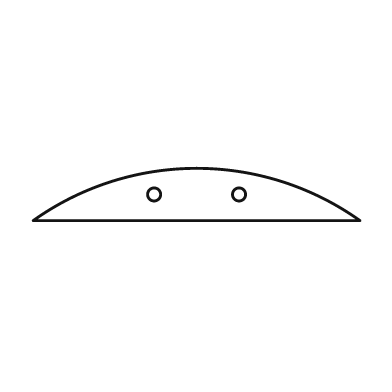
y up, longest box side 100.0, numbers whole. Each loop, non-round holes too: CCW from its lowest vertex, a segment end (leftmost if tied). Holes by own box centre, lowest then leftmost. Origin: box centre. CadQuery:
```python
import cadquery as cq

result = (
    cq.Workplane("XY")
    .moveTo(-50.0, -8.0)
    .lineTo(50.0, -8.0)
    .threePointArc((0.0, 8.0), (-50.0, -8.0))
    .close()
    .moveTo(-13.0, 0.0)
    .circle(2.0)
    .moveTo(13.0, 0.0)
    .circle(2.0)
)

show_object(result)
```